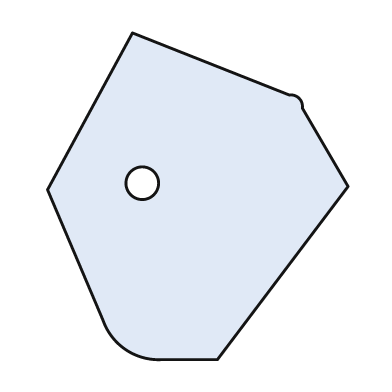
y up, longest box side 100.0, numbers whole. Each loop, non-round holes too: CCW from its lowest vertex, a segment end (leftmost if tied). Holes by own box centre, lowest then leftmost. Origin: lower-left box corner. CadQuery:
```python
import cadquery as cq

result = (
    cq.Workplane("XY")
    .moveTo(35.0, 0.0)
    .lineTo(52.0, 0.0)
    .lineTo(92.0, 53.0)
    .lineTo(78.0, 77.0)
    .threePointArc((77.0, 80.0), (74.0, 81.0))
    .lineTo(26.0, 100.0)
    .lineTo(0.0, 52.0)
    .lineTo(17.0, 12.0)
    .threePointArc((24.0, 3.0), (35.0, 0.0))
    .close()
    .moveTo(29.0, 54.0)
    .circle(5.0)
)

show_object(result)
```